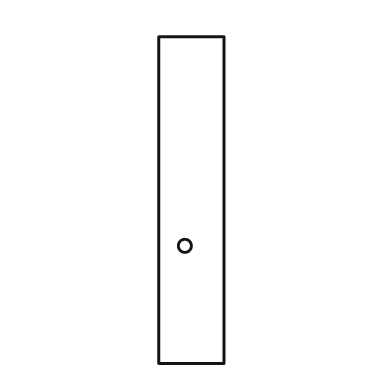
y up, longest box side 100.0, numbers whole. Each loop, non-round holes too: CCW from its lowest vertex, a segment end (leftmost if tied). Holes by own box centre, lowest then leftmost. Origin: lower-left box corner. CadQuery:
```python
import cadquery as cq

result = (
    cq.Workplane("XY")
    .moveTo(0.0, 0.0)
    .lineTo(20.0, 0.0)
    .lineTo(20.0, 100.0)
    .lineTo(0.0, 100.0)
    .close()
    .moveTo(8.0, 36.0)
    .circle(2.0)
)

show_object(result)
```